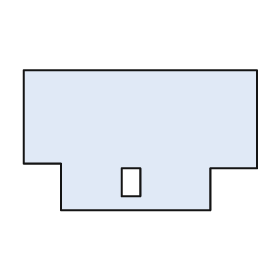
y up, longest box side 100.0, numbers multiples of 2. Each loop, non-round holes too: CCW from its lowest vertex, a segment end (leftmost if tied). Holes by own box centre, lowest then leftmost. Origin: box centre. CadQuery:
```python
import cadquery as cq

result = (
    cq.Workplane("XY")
    .moveTo(-34.0, -30.0)
    .lineTo(30.0, -30.0)
    .lineTo(30.0, -12.0)
    .lineTo(50.0, -12.0)
    .lineTo(50.0, 30.0)
    .lineTo(-50.0, 30.0)
    .lineTo(-50.0, -10.0)
    .lineTo(-34.0, -10.0)
    .close()
    .moveTo(-8.0, -24.0)
    .lineTo(0.0, -24.0)
    .lineTo(0.0, -12.0)
    .lineTo(-8.0, -12.0)
    .close()
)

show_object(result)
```